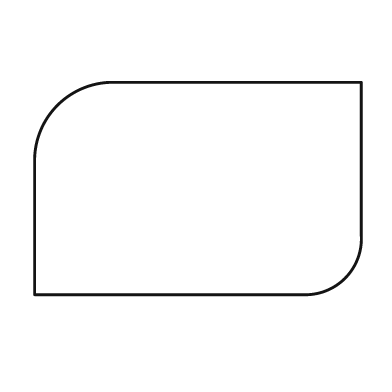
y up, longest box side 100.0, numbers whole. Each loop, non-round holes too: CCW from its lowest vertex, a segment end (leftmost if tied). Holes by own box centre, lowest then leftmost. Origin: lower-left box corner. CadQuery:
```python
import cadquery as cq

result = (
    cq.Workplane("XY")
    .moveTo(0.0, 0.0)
    .lineTo(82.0, 0.0)
    .threePointArc((95.0, 5.0), (100.0, 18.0))
    .lineTo(100.0, 65.0)
    .lineTo(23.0, 65.0)
    .threePointArc((7.0, 58.0), (0.0, 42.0))
    .close()
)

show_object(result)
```